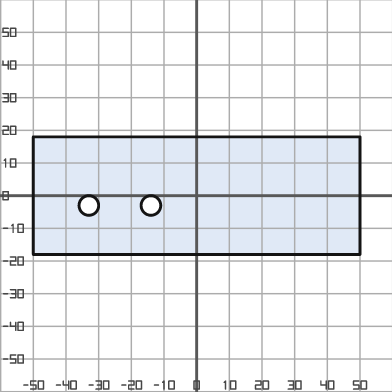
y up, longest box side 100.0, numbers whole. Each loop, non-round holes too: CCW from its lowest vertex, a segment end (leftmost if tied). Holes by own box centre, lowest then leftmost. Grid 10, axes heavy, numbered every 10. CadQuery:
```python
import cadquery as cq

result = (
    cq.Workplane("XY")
    .moveTo(-50.0, -18.0)
    .lineTo(50.0, -18.0)
    .lineTo(50.0, 18.0)
    .lineTo(-50.0, 18.0)
    .close()
    .moveTo(-33.0, -3.0)
    .circle(3.0)
    .moveTo(-14.0, -3.0)
    .circle(3.0)
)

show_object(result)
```